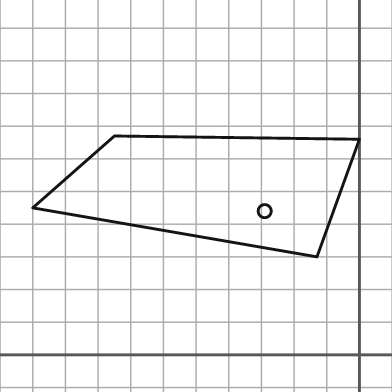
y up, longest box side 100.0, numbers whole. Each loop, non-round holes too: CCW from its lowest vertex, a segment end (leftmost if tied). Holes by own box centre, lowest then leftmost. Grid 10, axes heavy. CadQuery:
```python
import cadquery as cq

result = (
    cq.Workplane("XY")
    .moveTo(-13.0, 30.0)
    .lineTo(0.0, 66.0)
    .lineTo(-75.0, 67.0)
    .lineTo(-100.0, 45.0)
    .close()
    .moveTo(-29.0, 44.0)
    .circle(2.0)
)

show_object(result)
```